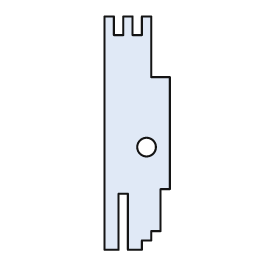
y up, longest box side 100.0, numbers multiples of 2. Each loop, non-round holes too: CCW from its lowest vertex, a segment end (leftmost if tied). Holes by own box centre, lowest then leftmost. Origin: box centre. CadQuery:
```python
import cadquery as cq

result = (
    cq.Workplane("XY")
    .moveTo(-14.0, -50.0)
    .lineTo(-8.0, -50.0)
    .lineTo(-8.0, -26.0)
    .lineTo(-4.0, -26.0)
    .lineTo(-4.0, -50.0)
    .lineTo(2.0, -50.0)
    .lineTo(2.0, -46.0)
    .lineTo(6.0, -46.0)
    .lineTo(6.0, -42.0)
    .lineTo(10.0, -42.0)
    .lineTo(10.0, -24.0)
    .lineTo(14.0, -24.0)
    .lineTo(14.0, 24.0)
    .lineTo(6.0, 24.0)
    .lineTo(6.0, 50.0)
    .lineTo(2.0, 50.0)
    .lineTo(2.0, 42.0)
    .lineTo(-2.0, 42.0)
    .lineTo(-2.0, 50.0)
    .lineTo(-6.0, 50.0)
    .lineTo(-6.0, 42.0)
    .lineTo(-10.0, 42.0)
    .lineTo(-10.0, 50.0)
    .lineTo(-14.0, 50.0)
    .close()
    .moveTo(4.0, -6.0)
    .circle(4.0)
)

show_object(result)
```